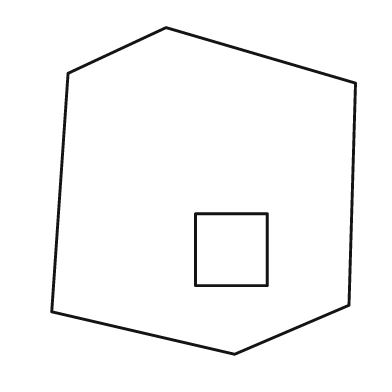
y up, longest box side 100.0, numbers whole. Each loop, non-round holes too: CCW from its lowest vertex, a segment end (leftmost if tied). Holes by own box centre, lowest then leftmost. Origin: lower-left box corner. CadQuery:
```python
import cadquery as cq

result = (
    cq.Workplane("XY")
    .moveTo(56.0, 0.0)
    .lineTo(91.0, 15.0)
    .lineTo(93.0, 83.0)
    .lineTo(35.0, 100.0)
    .lineTo(5.0, 86.0)
    .lineTo(0.0, 13.0)
    .close()
    .moveTo(44.0, 21.0)
    .lineTo(66.0, 21.0)
    .lineTo(66.0, 43.0)
    .lineTo(44.0, 43.0)
    .close()
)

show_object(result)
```